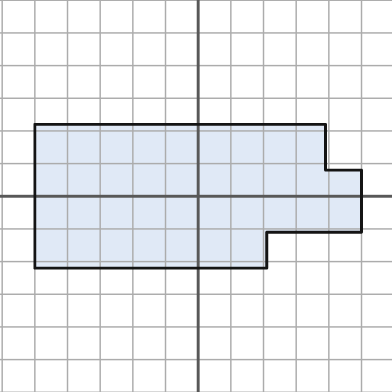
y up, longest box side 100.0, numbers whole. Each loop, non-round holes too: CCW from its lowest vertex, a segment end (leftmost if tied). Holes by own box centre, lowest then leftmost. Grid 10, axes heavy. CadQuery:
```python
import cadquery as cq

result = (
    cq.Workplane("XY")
    .moveTo(-50.0, -22.0)
    .lineTo(21.0, -22.0)
    .lineTo(21.0, -11.0)
    .lineTo(50.0, -11.0)
    .lineTo(50.0, 8.0)
    .lineTo(39.0, 8.0)
    .lineTo(39.0, 22.0)
    .lineTo(-50.0, 22.0)
    .close()
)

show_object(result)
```